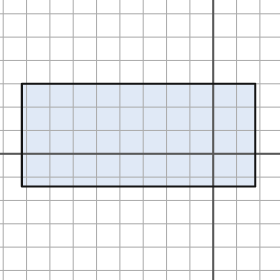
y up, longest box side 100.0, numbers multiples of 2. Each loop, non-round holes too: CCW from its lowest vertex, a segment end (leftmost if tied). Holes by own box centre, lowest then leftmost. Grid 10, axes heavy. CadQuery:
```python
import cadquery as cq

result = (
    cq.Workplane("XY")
    .moveTo(-82.0, -14.0)
    .lineTo(18.0, -14.0)
    .lineTo(18.0, 30.0)
    .lineTo(-82.0, 30.0)
    .close()
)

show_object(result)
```